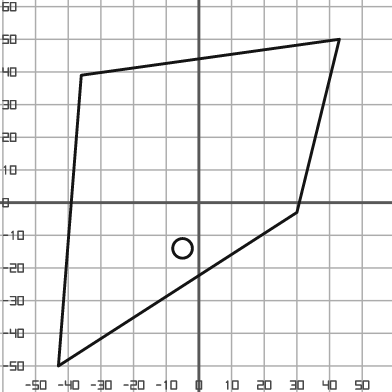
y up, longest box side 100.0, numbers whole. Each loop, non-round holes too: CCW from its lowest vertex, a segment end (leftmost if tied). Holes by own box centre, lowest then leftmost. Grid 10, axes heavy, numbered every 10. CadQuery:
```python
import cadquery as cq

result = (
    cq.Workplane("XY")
    .moveTo(-43.0, -50.0)
    .lineTo(30.0, -3.0)
    .lineTo(43.0, 50.0)
    .lineTo(-36.0, 39.0)
    .close()
    .moveTo(-5.0, -14.0)
    .circle(3.0)
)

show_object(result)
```